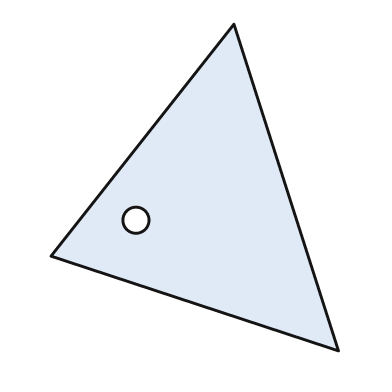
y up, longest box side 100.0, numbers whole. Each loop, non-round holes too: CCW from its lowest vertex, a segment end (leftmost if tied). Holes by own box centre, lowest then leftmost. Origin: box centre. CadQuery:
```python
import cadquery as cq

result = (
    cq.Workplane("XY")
    .moveTo(44.0, -50.0)
    .lineTo(12.0, 50.0)
    .lineTo(-44.0, -21.0)
    .close()
    .moveTo(-18.0, -10.0)
    .circle(4.0)
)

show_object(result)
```